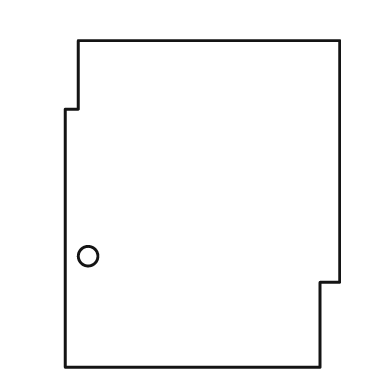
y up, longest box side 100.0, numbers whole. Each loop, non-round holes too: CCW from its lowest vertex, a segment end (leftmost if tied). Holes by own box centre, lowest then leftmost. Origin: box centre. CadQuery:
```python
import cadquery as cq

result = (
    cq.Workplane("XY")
    .moveTo(-42.0, -50.0)
    .lineTo(36.0, -50.0)
    .lineTo(36.0, -24.0)
    .lineTo(42.0, -24.0)
    .lineTo(42.0, 50.0)
    .lineTo(-38.0, 50.0)
    .lineTo(-38.0, 29.0)
    .lineTo(-42.0, 29.0)
    .close()
    .moveTo(-35.0, -16.0)
    .circle(3.0)
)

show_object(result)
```